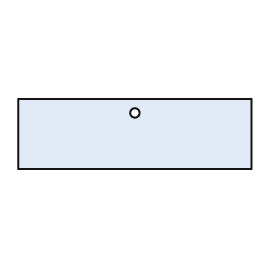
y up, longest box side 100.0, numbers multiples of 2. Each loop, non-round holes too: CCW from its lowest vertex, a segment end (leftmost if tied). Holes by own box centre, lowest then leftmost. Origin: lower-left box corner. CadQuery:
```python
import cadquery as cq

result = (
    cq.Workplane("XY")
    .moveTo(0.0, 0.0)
    .lineTo(100.0, 0.0)
    .lineTo(100.0, 30.0)
    .lineTo(0.0, 30.0)
    .close()
    .moveTo(50.0, 24.0)
    .circle(2.0)
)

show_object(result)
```